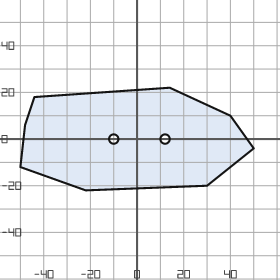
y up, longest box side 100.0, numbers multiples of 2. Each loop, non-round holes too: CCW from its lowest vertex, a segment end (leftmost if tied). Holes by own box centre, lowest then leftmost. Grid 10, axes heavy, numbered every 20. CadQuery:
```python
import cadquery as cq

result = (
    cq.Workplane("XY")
    .moveTo(-22.0, -22.0)
    .lineTo(30.0, -20.0)
    .lineTo(50.0, -4.0)
    .lineTo(40.0, 10.0)
    .lineTo(14.0, 22.0)
    .lineTo(-44.0, 18.0)
    .lineTo(-48.0, 6.0)
    .lineTo(-50.0, -12.0)
    .close()
    .moveTo(-10.0, 0.0)
    .circle(2.0)
    .moveTo(12.0, 0.0)
    .circle(2.0)
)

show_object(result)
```